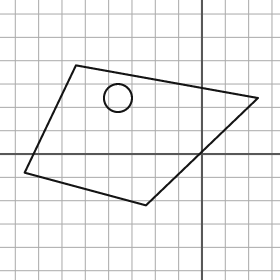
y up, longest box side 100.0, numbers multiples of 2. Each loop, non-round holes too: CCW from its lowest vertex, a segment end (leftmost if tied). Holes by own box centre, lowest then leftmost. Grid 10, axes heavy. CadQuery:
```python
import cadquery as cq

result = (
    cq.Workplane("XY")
    .moveTo(-24.0, -22.0)
    .lineTo(24.0, 24.0)
    .lineTo(-54.0, 38.0)
    .lineTo(-76.0, -8.0)
    .close()
    .moveTo(-36.0, 24.0)
    .circle(6.0)
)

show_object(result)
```